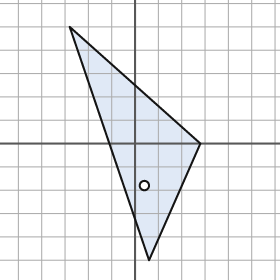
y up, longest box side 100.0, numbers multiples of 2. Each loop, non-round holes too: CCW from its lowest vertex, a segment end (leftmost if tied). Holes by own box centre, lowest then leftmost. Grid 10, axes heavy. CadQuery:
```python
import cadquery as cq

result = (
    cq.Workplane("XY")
    .moveTo(6.0, -50.0)
    .lineTo(28.0, 0.0)
    .lineTo(-28.0, 50.0)
    .close()
    .moveTo(4.0, -18.0)
    .circle(2.0)
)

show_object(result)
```